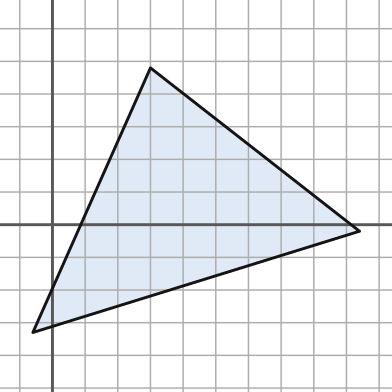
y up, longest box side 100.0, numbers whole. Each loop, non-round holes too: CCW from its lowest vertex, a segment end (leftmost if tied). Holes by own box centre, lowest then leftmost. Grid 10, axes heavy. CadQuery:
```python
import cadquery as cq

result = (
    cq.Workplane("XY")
    .moveTo(-6.0, -33.0)
    .lineTo(94.0, -2.0)
    .lineTo(30.0, 48.0)
    .close()
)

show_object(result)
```